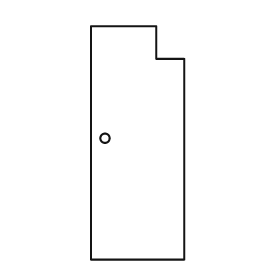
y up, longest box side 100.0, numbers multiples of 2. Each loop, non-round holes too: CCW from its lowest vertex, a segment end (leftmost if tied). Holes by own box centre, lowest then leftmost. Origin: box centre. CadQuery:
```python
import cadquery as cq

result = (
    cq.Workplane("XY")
    .moveTo(-20.0, -50.0)
    .lineTo(20.0, -50.0)
    .lineTo(20.0, 36.0)
    .lineTo(8.0, 36.0)
    .lineTo(8.0, 50.0)
    .lineTo(-20.0, 50.0)
    .close()
    .moveTo(-14.0, 2.0)
    .circle(2.0)
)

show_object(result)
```